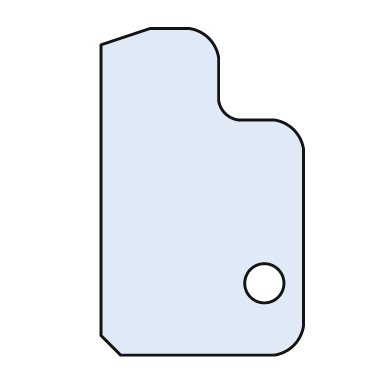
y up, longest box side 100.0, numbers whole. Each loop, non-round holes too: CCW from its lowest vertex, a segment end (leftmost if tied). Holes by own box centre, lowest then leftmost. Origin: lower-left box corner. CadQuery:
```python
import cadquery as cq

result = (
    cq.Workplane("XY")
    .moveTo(6.0, 0.0)
    .lineTo(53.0, 0.0)
    .threePointArc((59.0, 3.0), (62.0, 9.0))
    .lineTo(62.0, 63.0)
    .threePointArc((59.0, 69.0), (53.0, 72.0))
    .lineTo(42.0, 72.0)
    .threePointArc((38.0, 74.0), (36.0, 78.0))
    .lineTo(36.0, 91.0)
    .threePointArc((33.0, 97.0), (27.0, 100.0))
    .lineTo(15.0, 100.0)
    .lineTo(0.0, 95.0)
    .lineTo(0.0, 6.0)
    .close()
    .moveTo(50.0, 22.0)
    .circle(6.0)
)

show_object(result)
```